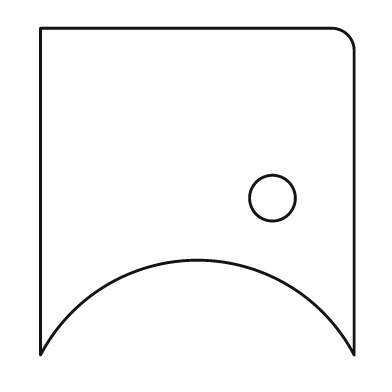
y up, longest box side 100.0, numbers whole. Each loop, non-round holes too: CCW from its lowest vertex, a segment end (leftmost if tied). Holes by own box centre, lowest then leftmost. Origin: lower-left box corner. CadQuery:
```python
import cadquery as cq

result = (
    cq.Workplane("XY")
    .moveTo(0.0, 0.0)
    .threePointArc((48.0, 29.0), (96.0, 0.0))
    .lineTo(96.0, 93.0)
    .threePointArc((94.0, 98.0), (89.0, 100.0))
    .lineTo(0.0, 100.0)
    .close()
    .moveTo(71.0, 48.0)
    .circle(7.0)
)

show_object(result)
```